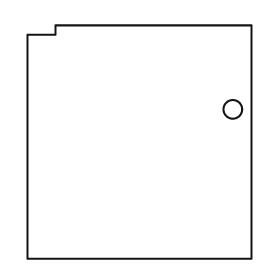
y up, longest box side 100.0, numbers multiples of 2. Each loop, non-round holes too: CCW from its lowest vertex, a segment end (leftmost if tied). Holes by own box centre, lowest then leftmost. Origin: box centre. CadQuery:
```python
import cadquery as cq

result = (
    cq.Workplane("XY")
    .moveTo(-48.0, -50.0)
    .lineTo(48.0, -50.0)
    .lineTo(48.0, 50.0)
    .lineTo(-36.0, 50.0)
    .lineTo(-36.0, 46.0)
    .lineTo(-48.0, 46.0)
    .close()
    .moveTo(40.0, 14.0)
    .circle(4.0)
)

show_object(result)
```